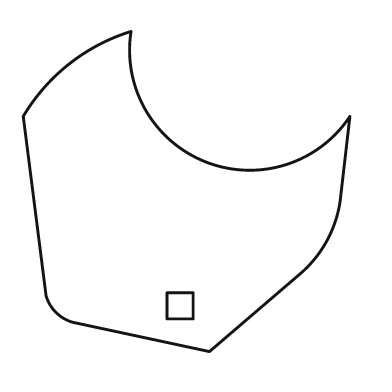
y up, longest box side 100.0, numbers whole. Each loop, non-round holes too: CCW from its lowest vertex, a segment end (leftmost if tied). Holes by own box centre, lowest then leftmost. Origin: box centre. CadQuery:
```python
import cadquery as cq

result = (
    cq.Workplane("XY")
    .moveTo(7.0, -49.0)
    .lineTo(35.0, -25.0)
    .threePointArc((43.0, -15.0), (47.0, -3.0))
    .lineTo(50.0, 23.0)
    .threePointArc((6.0, 9.0), (-17.0, 49.0))
    .threePointArc((-36.0, 39.0), (-50.0, 23.0))
    .lineTo(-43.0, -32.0)
    .threePointArc((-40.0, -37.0), (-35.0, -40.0))
    .close()
    .moveTo(-6.0, -39.0)
    .lineTo(2.0, -39.0)
    .lineTo(2.0, -31.0)
    .lineTo(-6.0, -31.0)
    .close()
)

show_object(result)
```